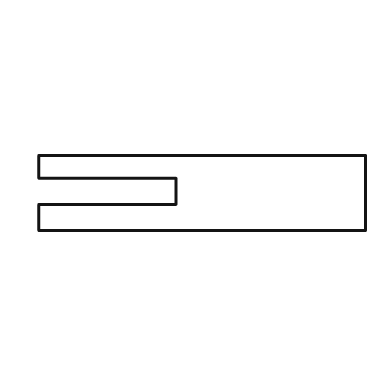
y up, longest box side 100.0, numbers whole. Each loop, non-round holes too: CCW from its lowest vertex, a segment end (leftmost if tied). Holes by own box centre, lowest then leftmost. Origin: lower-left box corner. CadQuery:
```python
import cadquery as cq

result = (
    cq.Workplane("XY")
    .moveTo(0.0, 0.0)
    .lineTo(100.0, 0.0)
    .lineTo(100.0, 23.0)
    .lineTo(0.0, 23.0)
    .lineTo(0.0, 16.0)
    .lineTo(42.0, 16.0)
    .lineTo(42.0, 8.0)
    .lineTo(0.0, 8.0)
    .close()
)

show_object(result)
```